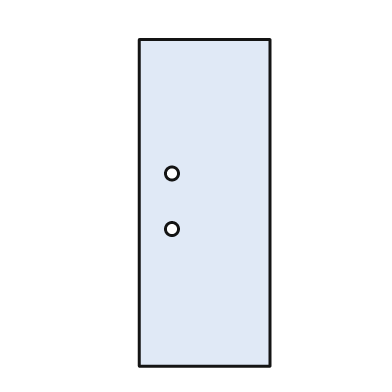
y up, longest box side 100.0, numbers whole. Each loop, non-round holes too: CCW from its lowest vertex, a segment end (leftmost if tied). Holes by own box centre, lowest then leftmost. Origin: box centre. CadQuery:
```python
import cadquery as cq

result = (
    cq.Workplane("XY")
    .moveTo(-20.0, -50.0)
    .lineTo(20.0, -50.0)
    .lineTo(20.0, 50.0)
    .lineTo(-20.0, 50.0)
    .close()
    .moveTo(-10.0, -8.0)
    .circle(2.0)
    .moveTo(-10.0, 9.0)
    .circle(2.0)
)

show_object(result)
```